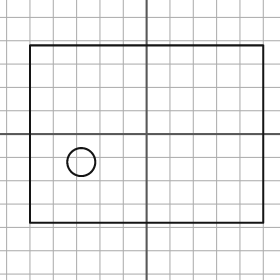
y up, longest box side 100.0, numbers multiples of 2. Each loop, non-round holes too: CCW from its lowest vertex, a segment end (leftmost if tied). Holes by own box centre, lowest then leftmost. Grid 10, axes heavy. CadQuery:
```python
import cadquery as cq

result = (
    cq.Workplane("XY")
    .moveTo(-50.0, -38.0)
    .lineTo(50.0, -38.0)
    .lineTo(50.0, 38.0)
    .lineTo(-50.0, 38.0)
    .close()
    .moveTo(-28.0, -12.0)
    .circle(6.0)
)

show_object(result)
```